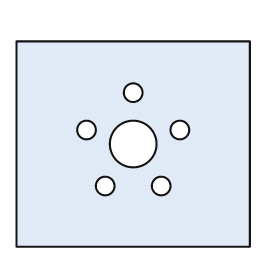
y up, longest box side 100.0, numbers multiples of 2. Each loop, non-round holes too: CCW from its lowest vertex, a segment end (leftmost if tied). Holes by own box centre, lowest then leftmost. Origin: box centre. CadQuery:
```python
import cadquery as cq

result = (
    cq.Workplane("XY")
    .moveTo(-50.0, -44.0)
    .lineTo(50.0, -44.0)
    .lineTo(50.0, 44.0)
    .lineTo(-50.0, 44.0)
    .close()
    .moveTo(-12.0, -18.0)
    .circle(4.0)
    .moveTo(12.0, -18.0)
    .circle(4.0)
    .moveTo(0.0, 0.0)
    .circle(10.0)
    .moveTo(-20.0, 6.0)
    .circle(4.0)
    .moveTo(20.0, 6.0)
    .circle(4.0)
    .moveTo(0.0, 22.0)
    .circle(4.0)
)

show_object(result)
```